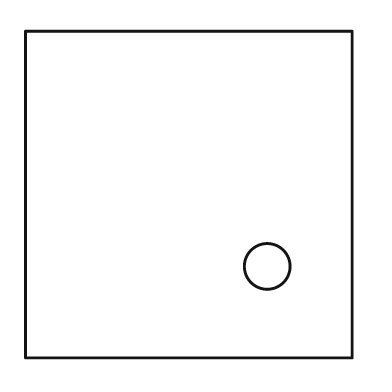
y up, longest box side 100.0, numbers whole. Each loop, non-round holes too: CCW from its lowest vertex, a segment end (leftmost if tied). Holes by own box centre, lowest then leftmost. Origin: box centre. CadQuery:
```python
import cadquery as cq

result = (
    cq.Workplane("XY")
    .moveTo(-50.0, -50.0)
    .lineTo(50.0, -50.0)
    .lineTo(50.0, 50.0)
    .lineTo(-50.0, 50.0)
    .close()
    .moveTo(24.0, -22.0)
    .circle(7.0)
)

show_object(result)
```